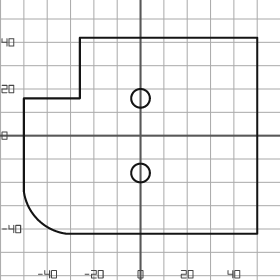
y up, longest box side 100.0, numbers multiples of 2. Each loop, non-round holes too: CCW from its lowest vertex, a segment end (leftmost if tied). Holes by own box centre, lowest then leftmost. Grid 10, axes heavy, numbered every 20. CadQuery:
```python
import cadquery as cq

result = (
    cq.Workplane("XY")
    .moveTo(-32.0, -42.0)
    .lineTo(50.0, -42.0)
    .lineTo(50.0, 42.0)
    .lineTo(-26.0, 42.0)
    .lineTo(-26.0, 16.0)
    .lineTo(-50.0, 16.0)
    .lineTo(-50.0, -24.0)
    .threePointArc((-44.0, -36.0), (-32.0, -42.0))
    .close()
    .moveTo(0.0, -16.0)
    .circle(4.0)
    .moveTo(0.0, 16.0)
    .circle(4.0)
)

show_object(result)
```